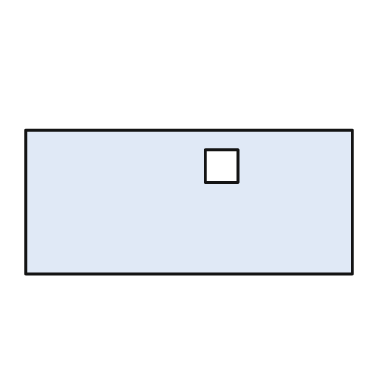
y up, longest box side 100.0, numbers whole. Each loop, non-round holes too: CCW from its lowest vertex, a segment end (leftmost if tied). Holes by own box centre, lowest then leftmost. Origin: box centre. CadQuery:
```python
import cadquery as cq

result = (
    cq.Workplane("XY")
    .moveTo(-50.0, -22.0)
    .lineTo(50.0, -22.0)
    .lineTo(50.0, 22.0)
    .lineTo(-50.0, 22.0)
    .close()
    .moveTo(5.0, 6.0)
    .lineTo(15.0, 6.0)
    .lineTo(15.0, 16.0)
    .lineTo(5.0, 16.0)
    .close()
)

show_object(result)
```